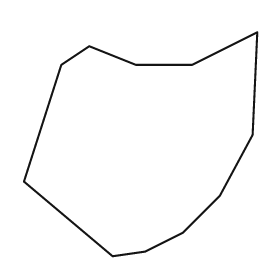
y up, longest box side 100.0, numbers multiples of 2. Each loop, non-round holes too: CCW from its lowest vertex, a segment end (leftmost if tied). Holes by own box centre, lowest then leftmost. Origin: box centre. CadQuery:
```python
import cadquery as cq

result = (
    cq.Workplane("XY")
    .moveTo(-12.0, -48.0)
    .lineTo(2.0, -46.0)
    .lineTo(18.0, -38.0)
    .lineTo(34.0, -22.0)
    .lineTo(48.0, 4.0)
    .lineTo(50.0, 48.0)
    .lineTo(22.0, 34.0)
    .lineTo(-2.0, 34.0)
    .lineTo(-22.0, 42.0)
    .lineTo(-34.0, 34.0)
    .lineTo(-50.0, -16.0)
    .close()
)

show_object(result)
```